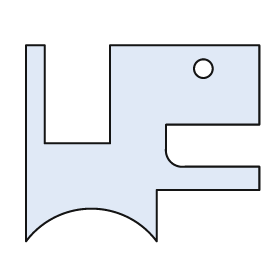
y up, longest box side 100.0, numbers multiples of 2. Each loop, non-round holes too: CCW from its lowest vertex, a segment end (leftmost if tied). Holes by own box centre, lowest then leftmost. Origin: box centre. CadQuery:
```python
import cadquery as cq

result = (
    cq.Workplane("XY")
    .moveTo(-50.0, -42.0)
    .threePointArc((-22.0, -28.0), (6.0, -42.0))
    .lineTo(6.0, -20.0)
    .lineTo(50.0, -20.0)
    .lineTo(50.0, -10.0)
    .lineTo(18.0, -10.0)
    .threePointArc((12.0, -8.0), (10.0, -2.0))
    .lineTo(10.0, 8.0)
    .lineTo(50.0, 8.0)
    .lineTo(50.0, 42.0)
    .lineTo(-14.0, 42.0)
    .lineTo(-14.0, 0.0)
    .lineTo(-42.0, 0.0)
    .lineTo(-42.0, 42.0)
    .lineTo(-50.0, 42.0)
    .close()
    .moveTo(26.0, 32.0)
    .circle(4.0)
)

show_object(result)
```